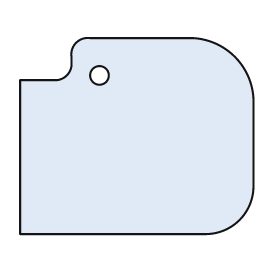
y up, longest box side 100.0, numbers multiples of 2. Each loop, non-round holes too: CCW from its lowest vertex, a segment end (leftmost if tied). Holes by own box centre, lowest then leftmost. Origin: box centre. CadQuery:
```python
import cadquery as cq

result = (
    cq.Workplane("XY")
    .moveTo(-50.0, -42.0)
    .lineTo(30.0, -42.0)
    .threePointArc((44.0, -36.0), (50.0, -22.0))
    .lineTo(50.0, 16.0)
    .threePointArc((42.0, 34.0), (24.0, 42.0))
    .lineTo(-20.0, 42.0)
    .threePointArc((-26.0, 40.0), (-28.0, 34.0))
    .lineTo(-28.0, 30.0)
    .threePointArc((-30.0, 26.0), (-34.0, 24.0))
    .lineTo(-50.0, 24.0)
    .close()
    .moveTo(-16.0, 26.0)
    .circle(4.0)
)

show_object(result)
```